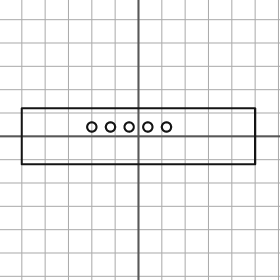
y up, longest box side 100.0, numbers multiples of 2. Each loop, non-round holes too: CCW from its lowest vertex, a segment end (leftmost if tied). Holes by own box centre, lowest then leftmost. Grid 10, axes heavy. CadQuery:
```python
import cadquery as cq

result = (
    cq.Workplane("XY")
    .moveTo(-50.0, -12.0)
    .lineTo(50.0, -12.0)
    .lineTo(50.0, 12.0)
    .lineTo(-50.0, 12.0)
    .close()
    .moveTo(-20.0, 4.0)
    .circle(2.0)
    .moveTo(-12.0, 4.0)
    .circle(2.0)
    .moveTo(-4.0, 4.0)
    .circle(2.0)
    .moveTo(4.0, 4.0)
    .circle(2.0)
    .moveTo(12.0, 4.0)
    .circle(2.0)
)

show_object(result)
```